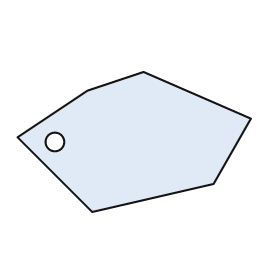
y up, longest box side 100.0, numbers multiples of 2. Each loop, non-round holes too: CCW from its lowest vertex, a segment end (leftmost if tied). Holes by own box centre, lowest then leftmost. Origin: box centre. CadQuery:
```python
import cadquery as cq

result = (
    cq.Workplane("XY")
    .moveTo(-18.0, -30.0)
    .lineTo(34.0, -18.0)
    .lineTo(50.0, 10.0)
    .lineTo(4.0, 30.0)
    .lineTo(-20.0, 22.0)
    .lineTo(-50.0, 2.0)
    .close()
    .moveTo(-34.0, 0.0)
    .circle(4.0)
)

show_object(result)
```